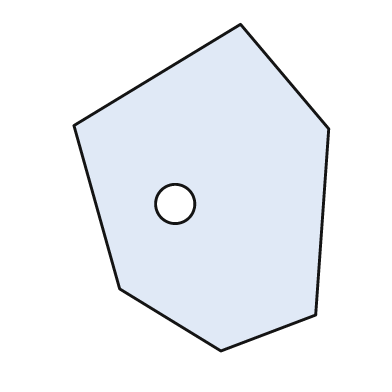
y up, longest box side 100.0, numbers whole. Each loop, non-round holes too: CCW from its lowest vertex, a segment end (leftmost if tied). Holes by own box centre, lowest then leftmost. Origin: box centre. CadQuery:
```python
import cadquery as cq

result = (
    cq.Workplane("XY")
    .moveTo(6.0, -50.0)
    .lineTo(35.0, -39.0)
    .lineTo(39.0, 18.0)
    .lineTo(12.0, 50.0)
    .lineTo(-39.0, 19.0)
    .lineTo(-25.0, -31.0)
    .close()
    .moveTo(-8.0, -5.0)
    .circle(6.0)
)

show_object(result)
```